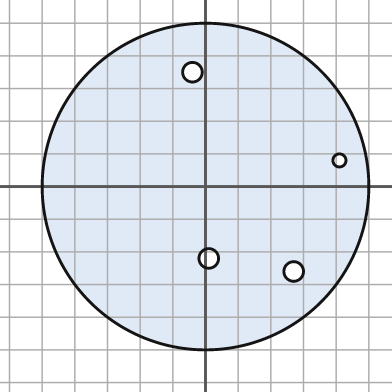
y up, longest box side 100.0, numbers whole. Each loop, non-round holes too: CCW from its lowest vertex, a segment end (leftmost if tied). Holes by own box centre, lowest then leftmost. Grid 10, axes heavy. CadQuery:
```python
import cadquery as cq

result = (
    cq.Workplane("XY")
    .moveTo(0.0, 0.0)
    .circle(50.0)
    .moveTo(27.0, -26.0)
    .circle(3.0)
    .moveTo(1.0, -22.0)
    .circle(3.0)
    .moveTo(41.0, 8.0)
    .circle(2.0)
    .moveTo(-4.0, 35.0)
    .circle(3.0)
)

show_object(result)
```